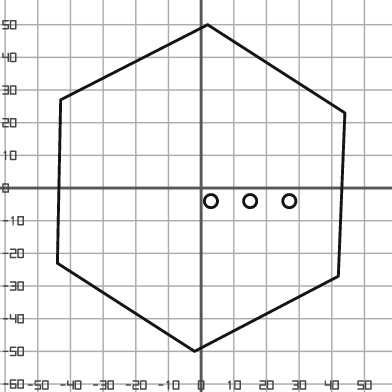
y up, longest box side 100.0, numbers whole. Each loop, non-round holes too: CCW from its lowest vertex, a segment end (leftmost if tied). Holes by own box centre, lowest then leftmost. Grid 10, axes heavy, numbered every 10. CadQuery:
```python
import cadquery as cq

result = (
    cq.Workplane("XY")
    .moveTo(-2.0, -50.0)
    .lineTo(42.0, -27.0)
    .lineTo(44.0, 23.0)
    .lineTo(2.0, 50.0)
    .lineTo(-43.0, 27.0)
    .lineTo(-44.0, -23.0)
    .close()
    .moveTo(3.0, -4.0)
    .circle(2.0)
    .moveTo(15.0, -4.0)
    .circle(2.0)
    .moveTo(27.0, -4.0)
    .circle(2.0)
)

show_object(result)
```